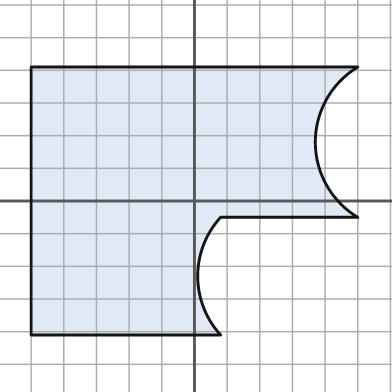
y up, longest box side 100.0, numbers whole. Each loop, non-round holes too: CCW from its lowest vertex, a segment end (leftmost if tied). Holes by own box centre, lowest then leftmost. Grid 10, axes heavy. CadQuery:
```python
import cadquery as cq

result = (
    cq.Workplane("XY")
    .moveTo(-50.0, -41.0)
    .lineTo(8.0, -41.0)
    .threePointArc((1.0, -23.0), (8.0, -5.0))
    .lineTo(50.0, -5.0)
    .threePointArc((37.0, 18.0), (50.0, 41.0))
    .lineTo(-50.0, 41.0)
    .close()
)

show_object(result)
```